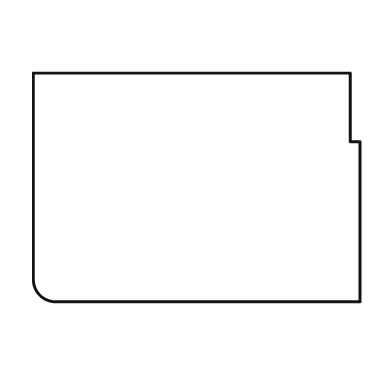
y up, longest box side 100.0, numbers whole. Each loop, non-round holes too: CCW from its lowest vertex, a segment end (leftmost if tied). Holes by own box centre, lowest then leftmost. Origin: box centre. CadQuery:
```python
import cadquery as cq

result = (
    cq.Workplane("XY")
    .moveTo(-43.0, -35.0)
    .lineTo(50.0, -35.0)
    .lineTo(50.0, 14.0)
    .lineTo(47.0, 14.0)
    .lineTo(47.0, 35.0)
    .lineTo(-50.0, 35.0)
    .lineTo(-50.0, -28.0)
    .threePointArc((-48.0, -33.0), (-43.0, -35.0))
    .close()
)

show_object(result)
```